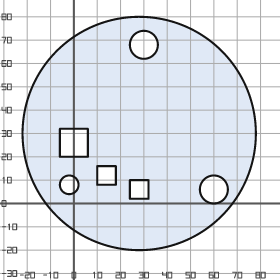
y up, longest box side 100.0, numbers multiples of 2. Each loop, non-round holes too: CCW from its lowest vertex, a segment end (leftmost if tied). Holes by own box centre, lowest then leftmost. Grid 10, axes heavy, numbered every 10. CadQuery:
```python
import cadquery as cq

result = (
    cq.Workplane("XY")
    .moveTo(28.0, 30.0)
    .circle(50.0)
    .moveTo(24.0, 2.0)
    .lineTo(32.0, 2.0)
    .lineTo(32.0, 10.0)
    .lineTo(24.0, 10.0)
    .close()
    .moveTo(60.0, 6.0)
    .circle(6.0)
    .moveTo(-2.0, 8.0)
    .circle(4.0)
    .moveTo(10.0, 8.0)
    .lineTo(18.0, 8.0)
    .lineTo(18.0, 16.0)
    .lineTo(10.0, 16.0)
    .close()
    .moveTo(-6.0, 20.0)
    .lineTo(6.0, 20.0)
    .lineTo(6.0, 32.0)
    .lineTo(-6.0, 32.0)
    .close()
    .moveTo(30.0, 68.0)
    .circle(6.0)
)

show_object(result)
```